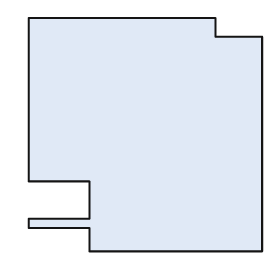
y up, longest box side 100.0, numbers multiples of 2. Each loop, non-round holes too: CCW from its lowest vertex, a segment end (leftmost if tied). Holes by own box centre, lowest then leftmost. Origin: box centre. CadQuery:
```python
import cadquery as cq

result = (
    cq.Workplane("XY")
    .moveTo(-24.0, -50.0)
    .lineTo(50.0, -50.0)
    .lineTo(50.0, 42.0)
    .lineTo(30.0, 42.0)
    .lineTo(30.0, 50.0)
    .lineTo(-50.0, 50.0)
    .lineTo(-50.0, -20.0)
    .lineTo(-24.0, -20.0)
    .lineTo(-24.0, -36.0)
    .lineTo(-50.0, -36.0)
    .lineTo(-50.0, -40.0)
    .lineTo(-24.0, -40.0)
    .close()
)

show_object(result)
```